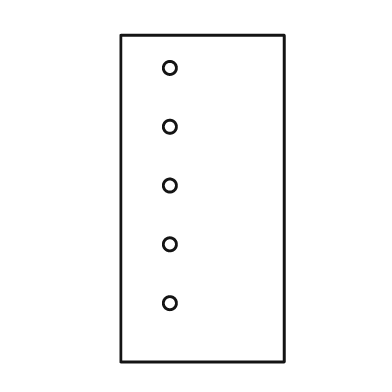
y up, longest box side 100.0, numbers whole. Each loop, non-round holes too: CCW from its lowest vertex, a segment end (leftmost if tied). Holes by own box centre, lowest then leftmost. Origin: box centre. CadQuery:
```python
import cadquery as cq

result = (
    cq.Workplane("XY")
    .moveTo(-25.0, -50.0)
    .lineTo(25.0, -50.0)
    .lineTo(25.0, 50.0)
    .lineTo(-25.0, 50.0)
    .close()
    .moveTo(-10.0, -32.0)
    .circle(2.0)
    .moveTo(-10.0, -14.0)
    .circle(2.0)
    .moveTo(-10.0, 4.0)
    .circle(2.0)
    .moveTo(-10.0, 22.0)
    .circle(2.0)
    .moveTo(-10.0, 40.0)
    .circle(2.0)
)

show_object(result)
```